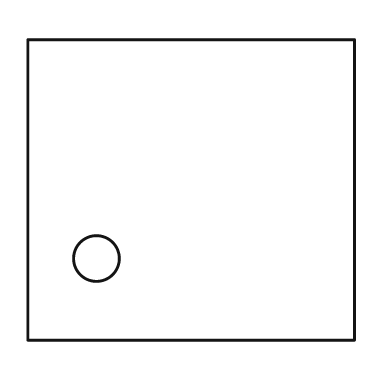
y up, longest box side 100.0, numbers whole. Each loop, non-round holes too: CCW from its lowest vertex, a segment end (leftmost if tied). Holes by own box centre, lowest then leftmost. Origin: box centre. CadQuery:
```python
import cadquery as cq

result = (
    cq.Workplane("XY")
    .moveTo(-50.0, -46.0)
    .lineTo(50.0, -46.0)
    .lineTo(50.0, 46.0)
    .lineTo(-50.0, 46.0)
    .close()
    .moveTo(-29.0, -21.0)
    .circle(7.0)
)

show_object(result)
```